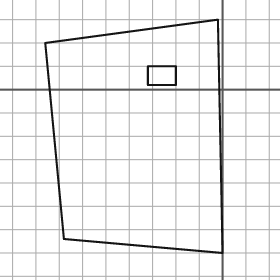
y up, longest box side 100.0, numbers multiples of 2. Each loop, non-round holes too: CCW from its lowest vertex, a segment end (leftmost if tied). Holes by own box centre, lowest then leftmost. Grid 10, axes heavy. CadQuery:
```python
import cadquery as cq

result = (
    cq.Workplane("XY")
    .moveTo(0.0, -70.0)
    .lineTo(-2.0, 30.0)
    .lineTo(-76.0, 20.0)
    .lineTo(-68.0, -64.0)
    .close()
    .moveTo(-32.0, 2.0)
    .lineTo(-20.0, 2.0)
    .lineTo(-20.0, 10.0)
    .lineTo(-32.0, 10.0)
    .close()
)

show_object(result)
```